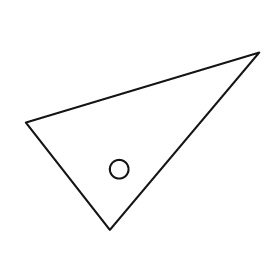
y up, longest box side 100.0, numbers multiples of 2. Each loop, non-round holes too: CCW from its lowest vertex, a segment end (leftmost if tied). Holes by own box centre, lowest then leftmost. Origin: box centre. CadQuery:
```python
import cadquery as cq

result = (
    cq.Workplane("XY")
    .moveTo(-14.0, -38.0)
    .lineTo(50.0, 38.0)
    .lineTo(-50.0, 8.0)
    .close()
    .moveTo(-10.0, -12.0)
    .circle(4.0)
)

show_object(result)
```